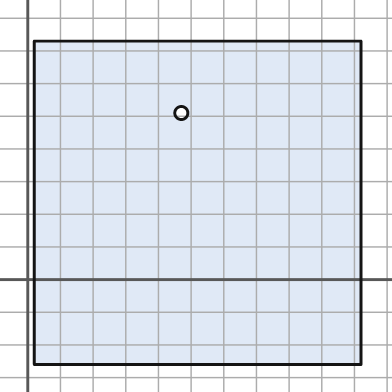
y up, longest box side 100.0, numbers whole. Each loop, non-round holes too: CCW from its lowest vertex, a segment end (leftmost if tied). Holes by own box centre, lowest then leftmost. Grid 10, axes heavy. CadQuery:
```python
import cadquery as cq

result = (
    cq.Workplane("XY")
    .moveTo(2.0, -26.0)
    .lineTo(102.0, -26.0)
    .lineTo(102.0, 73.0)
    .lineTo(2.0, 73.0)
    .close()
    .moveTo(47.0, 51.0)
    .circle(2.0)
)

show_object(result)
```